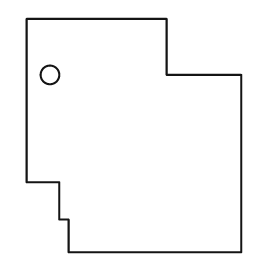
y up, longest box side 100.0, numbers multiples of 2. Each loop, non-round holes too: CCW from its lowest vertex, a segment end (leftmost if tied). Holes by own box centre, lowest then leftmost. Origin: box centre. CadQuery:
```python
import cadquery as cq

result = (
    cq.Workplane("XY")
    .moveTo(-28.0, -50.0)
    .lineTo(46.0, -50.0)
    .lineTo(46.0, 26.0)
    .lineTo(14.0, 26.0)
    .lineTo(14.0, 50.0)
    .lineTo(-46.0, 50.0)
    .lineTo(-46.0, -20.0)
    .lineTo(-32.0, -20.0)
    .lineTo(-32.0, -36.0)
    .lineTo(-28.0, -36.0)
    .close()
    .moveTo(-36.0, 26.0)
    .circle(4.0)
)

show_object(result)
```